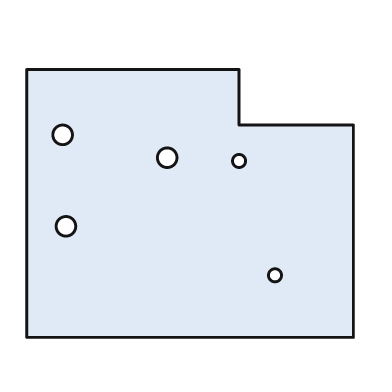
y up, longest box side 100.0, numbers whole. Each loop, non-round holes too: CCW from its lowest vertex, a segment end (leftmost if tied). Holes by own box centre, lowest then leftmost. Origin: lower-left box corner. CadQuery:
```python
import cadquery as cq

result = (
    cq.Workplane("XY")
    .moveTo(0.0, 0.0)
    .lineTo(100.0, 0.0)
    .lineTo(100.0, 65.0)
    .lineTo(65.0, 65.0)
    .lineTo(65.0, 82.0)
    .lineTo(0.0, 82.0)
    .close()
    .moveTo(76.0, 19.0)
    .circle(2.0)
    .moveTo(12.0, 34.0)
    .circle(3.0)
    .moveTo(65.0, 54.0)
    .circle(2.0)
    .moveTo(43.0, 55.0)
    .circle(3.0)
    .moveTo(11.0, 62.0)
    .circle(3.0)
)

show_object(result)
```